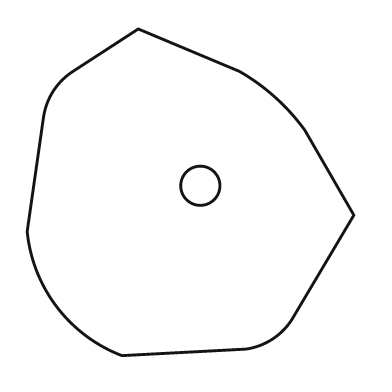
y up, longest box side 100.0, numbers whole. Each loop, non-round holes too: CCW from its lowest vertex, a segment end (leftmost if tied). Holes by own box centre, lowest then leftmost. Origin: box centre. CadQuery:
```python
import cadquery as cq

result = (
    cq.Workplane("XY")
    .moveTo(-21.0, -50.0)
    .lineTo(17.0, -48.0)
    .threePointArc((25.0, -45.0), (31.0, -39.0))
    .lineTo(50.0, -7.0)
    .lineTo(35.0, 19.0)
    .threePointArc((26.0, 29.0), (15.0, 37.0))
    .lineTo(-16.0, 50.0)
    .lineTo(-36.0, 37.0)
    .threePointArc((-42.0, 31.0), (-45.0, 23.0))
    .lineTo(-50.0, -12.0)
    .threePointArc((-41.0, -35.0), (-21.0, -50.0))
    .close()
    .moveTo(3.0, 2.0)
    .circle(6.0)
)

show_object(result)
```